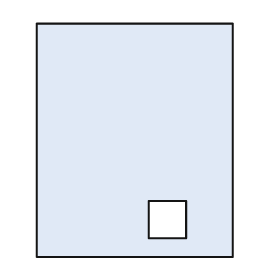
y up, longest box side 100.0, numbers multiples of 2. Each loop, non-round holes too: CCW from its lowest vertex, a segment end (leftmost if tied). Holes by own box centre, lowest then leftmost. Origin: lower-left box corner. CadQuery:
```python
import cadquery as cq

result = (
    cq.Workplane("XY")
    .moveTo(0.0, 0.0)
    .lineTo(84.0, 0.0)
    .lineTo(84.0, 100.0)
    .lineTo(0.0, 100.0)
    .close()
    .moveTo(48.0, 8.0)
    .lineTo(64.0, 8.0)
    .lineTo(64.0, 24.0)
    .lineTo(48.0, 24.0)
    .close()
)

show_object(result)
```